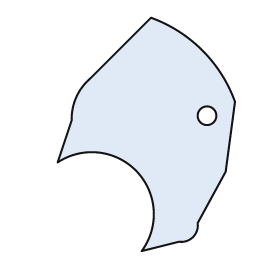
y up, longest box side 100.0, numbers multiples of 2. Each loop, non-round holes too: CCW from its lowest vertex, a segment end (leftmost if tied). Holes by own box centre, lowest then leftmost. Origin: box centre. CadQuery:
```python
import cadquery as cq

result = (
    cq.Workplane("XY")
    .moveTo(-2.0, -50.0)
    .lineTo(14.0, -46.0)
    .threePointArc((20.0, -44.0), (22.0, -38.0))
    .lineTo(34.0, -16.0)
    .lineTo(38.0, 14.0)
    .threePointArc((24.0, 36.0), (2.0, 50.0))
    .lineTo(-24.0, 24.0)
    .threePointArc((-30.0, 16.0), (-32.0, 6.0))
    .lineTo(-38.0, -12.0)
    .threePointArc((-4.0, -16.0), (-2.0, -50.0))
    .close()
    .moveTo(26.0, 8.0)
    .circle(4.0)
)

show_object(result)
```